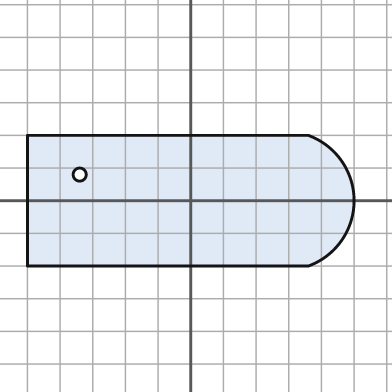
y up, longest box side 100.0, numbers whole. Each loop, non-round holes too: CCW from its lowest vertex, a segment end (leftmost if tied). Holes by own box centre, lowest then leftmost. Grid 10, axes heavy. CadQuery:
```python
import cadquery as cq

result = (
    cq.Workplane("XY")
    .moveTo(-50.0, -20.0)
    .lineTo(36.0, -20.0)
    .threePointArc((50.0, 0.0), (36.0, 20.0))
    .lineTo(-50.0, 20.0)
    .close()
    .moveTo(-34.0, 8.0)
    .circle(2.0)
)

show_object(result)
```